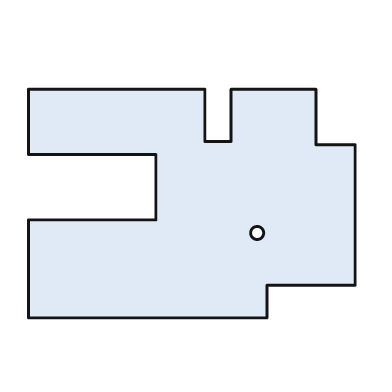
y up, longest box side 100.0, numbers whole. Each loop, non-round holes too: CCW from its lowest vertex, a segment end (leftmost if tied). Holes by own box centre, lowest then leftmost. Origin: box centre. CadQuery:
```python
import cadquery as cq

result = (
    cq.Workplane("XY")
    .moveTo(-50.0, -35.0)
    .lineTo(23.0, -35.0)
    .lineTo(23.0, -25.0)
    .lineTo(50.0, -25.0)
    .lineTo(50.0, 18.0)
    .lineTo(38.0, 18.0)
    .lineTo(38.0, 35.0)
    .lineTo(12.0, 35.0)
    .lineTo(12.0, 19.0)
    .lineTo(4.0, 19.0)
    .lineTo(4.0, 35.0)
    .lineTo(-50.0, 35.0)
    .lineTo(-50.0, 15.0)
    .lineTo(-11.0, 15.0)
    .lineTo(-11.0, -5.0)
    .lineTo(-50.0, -5.0)
    .close()
    .moveTo(20.0, -9.0)
    .circle(2.0)
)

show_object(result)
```